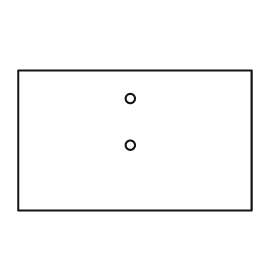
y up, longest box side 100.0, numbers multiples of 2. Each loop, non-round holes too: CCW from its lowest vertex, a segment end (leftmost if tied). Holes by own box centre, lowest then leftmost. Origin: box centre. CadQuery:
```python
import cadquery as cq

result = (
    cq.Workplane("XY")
    .moveTo(-50.0, -30.0)
    .lineTo(50.0, -30.0)
    .lineTo(50.0, 30.0)
    .lineTo(-50.0, 30.0)
    .close()
    .moveTo(-2.0, -2.0)
    .circle(2.0)
    .moveTo(-2.0, 18.0)
    .circle(2.0)
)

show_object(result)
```